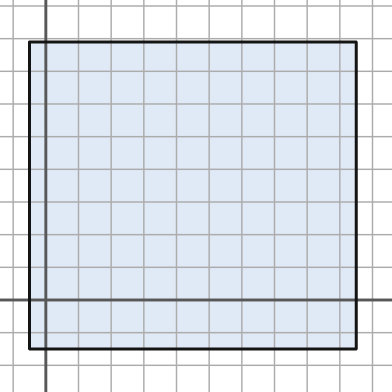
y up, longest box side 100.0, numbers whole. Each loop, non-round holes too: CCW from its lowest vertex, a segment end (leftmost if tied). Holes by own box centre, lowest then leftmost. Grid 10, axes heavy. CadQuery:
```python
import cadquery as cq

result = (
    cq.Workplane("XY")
    .moveTo(-5.0, -15.0)
    .lineTo(95.0, -15.0)
    .lineTo(95.0, 79.0)
    .lineTo(-5.0, 79.0)
    .close()
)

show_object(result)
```